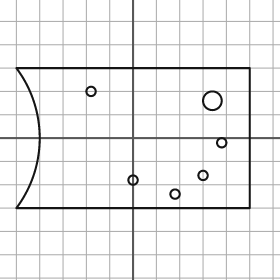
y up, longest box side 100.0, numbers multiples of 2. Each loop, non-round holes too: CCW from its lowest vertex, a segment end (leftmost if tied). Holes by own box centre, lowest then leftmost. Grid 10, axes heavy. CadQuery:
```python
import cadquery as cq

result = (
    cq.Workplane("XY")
    .moveTo(-50.0, -30.0)
    .lineTo(50.0, -30.0)
    .lineTo(50.0, 30.0)
    .lineTo(-50.0, 30.0)
    .threePointArc((-40.0, 0.0), (-50.0, -30.0))
    .close()
    .moveTo(18.0, -24.0)
    .circle(2.0)
    .moveTo(0.0, -18.0)
    .circle(2.0)
    .moveTo(30.0, -16.0)
    .circle(2.0)
    .moveTo(38.0, -2.0)
    .circle(2.0)
    .moveTo(34.0, 16.0)
    .circle(4.0)
    .moveTo(-18.0, 20.0)
    .circle(2.0)
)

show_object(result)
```